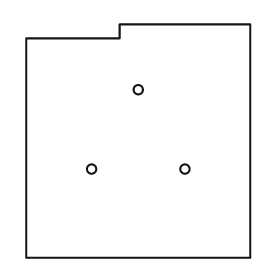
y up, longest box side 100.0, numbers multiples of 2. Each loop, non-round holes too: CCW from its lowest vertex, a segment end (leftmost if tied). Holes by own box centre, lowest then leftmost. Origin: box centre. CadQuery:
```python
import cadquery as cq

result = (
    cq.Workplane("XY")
    .moveTo(-48.0, -50.0)
    .lineTo(48.0, -50.0)
    .lineTo(48.0, 50.0)
    .lineTo(-8.0, 50.0)
    .lineTo(-8.0, 44.0)
    .lineTo(-48.0, 44.0)
    .close()
    .moveTo(-20.0, -12.0)
    .circle(2.0)
    .moveTo(20.0, -12.0)
    .circle(2.0)
    .moveTo(0.0, 22.0)
    .circle(2.0)
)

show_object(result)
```